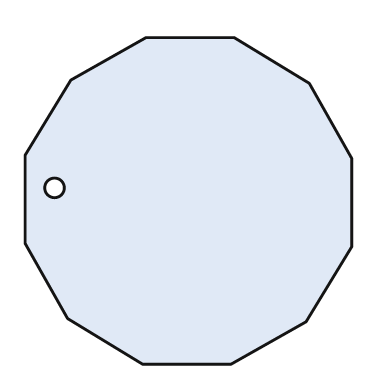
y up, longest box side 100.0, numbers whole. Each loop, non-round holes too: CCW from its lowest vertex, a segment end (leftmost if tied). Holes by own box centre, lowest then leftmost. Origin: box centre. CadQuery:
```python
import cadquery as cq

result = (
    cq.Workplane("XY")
    .moveTo(-14.0, -50.0)
    .lineTo(13.0, -50.0)
    .lineTo(36.0, -37.0)
    .lineTo(50.0, -14.0)
    .lineTo(50.0, 13.0)
    .lineTo(37.0, 36.0)
    .lineTo(14.0, 50.0)
    .lineTo(-13.0, 50.0)
    .lineTo(-36.0, 37.0)
    .lineTo(-50.0, 14.0)
    .lineTo(-50.0, -13.0)
    .lineTo(-37.0, -36.0)
    .close()
    .moveTo(-41.0, 4.0)
    .circle(3.0)
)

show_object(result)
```